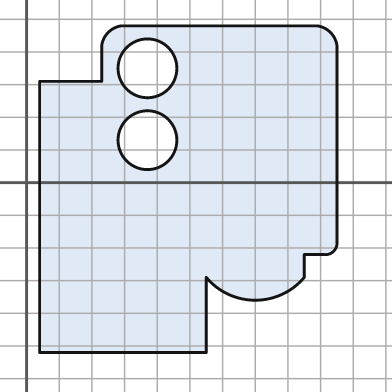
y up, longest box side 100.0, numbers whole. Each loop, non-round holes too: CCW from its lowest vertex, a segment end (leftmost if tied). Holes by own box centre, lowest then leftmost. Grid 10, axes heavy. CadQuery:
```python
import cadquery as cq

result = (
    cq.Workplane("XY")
    .moveTo(4.0, -52.0)
    .lineTo(55.0, -52.0)
    .lineTo(55.0, -29.0)
    .threePointArc((70.0, -36.0), (85.0, -29.0))
    .lineTo(85.0, -22.0)
    .lineTo(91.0, -22.0)
    .threePointArc((94.0, -21.0), (95.0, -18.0))
    .lineTo(95.0, 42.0)
    .threePointArc((93.0, 46.0), (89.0, 48.0))
    .lineTo(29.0, 48.0)
    .threePointArc((25.0, 46.0), (23.0, 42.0))
    .lineTo(23.0, 31.0)
    .lineTo(4.0, 31.0)
    .close()
    .moveTo(37.0, 13.0)
    .circle(9.0)
    .moveTo(37.0, 35.0)
    .circle(9.0)
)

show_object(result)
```